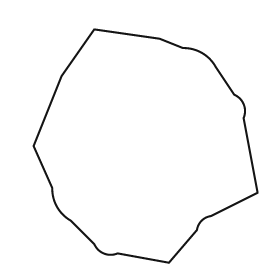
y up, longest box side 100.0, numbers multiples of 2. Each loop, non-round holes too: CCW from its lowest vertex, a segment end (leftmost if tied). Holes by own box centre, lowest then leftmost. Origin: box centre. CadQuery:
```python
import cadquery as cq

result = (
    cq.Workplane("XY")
    .moveTo(10.0, -50.0)
    .lineTo(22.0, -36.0)
    .threePointArc((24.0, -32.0), (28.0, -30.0))
    .lineTo(48.0, -20.0)
    .lineTo(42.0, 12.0)
    .threePointArc((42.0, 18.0), (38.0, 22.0))
    .lineTo(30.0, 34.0)
    .threePointArc((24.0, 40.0), (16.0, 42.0))
    .lineTo(6.0, 46.0)
    .lineTo(-22.0, 50.0)
    .lineTo(-36.0, 30.0)
    .lineTo(-48.0, 0.0)
    .lineTo(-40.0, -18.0)
    .threePointArc((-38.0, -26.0), (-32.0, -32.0))
    .lineTo(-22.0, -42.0)
    .threePointArc((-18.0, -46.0), (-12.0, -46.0))
    .close()
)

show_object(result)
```